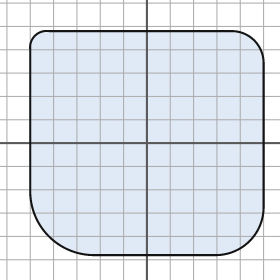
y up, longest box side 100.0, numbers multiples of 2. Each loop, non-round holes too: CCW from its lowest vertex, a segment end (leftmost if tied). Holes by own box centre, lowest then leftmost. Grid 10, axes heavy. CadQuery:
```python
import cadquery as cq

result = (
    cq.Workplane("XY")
    .moveTo(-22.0, -48.0)
    .lineTo(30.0, -48.0)
    .threePointArc((44.0, -42.0), (50.0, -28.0))
    .lineTo(50.0, 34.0)
    .threePointArc((46.0, 44.0), (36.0, 48.0))
    .lineTo(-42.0, 48.0)
    .threePointArc((-48.0, 46.0), (-50.0, 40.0))
    .lineTo(-50.0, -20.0)
    .threePointArc((-42.0, -40.0), (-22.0, -48.0))
    .close()
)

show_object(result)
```